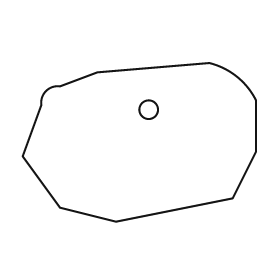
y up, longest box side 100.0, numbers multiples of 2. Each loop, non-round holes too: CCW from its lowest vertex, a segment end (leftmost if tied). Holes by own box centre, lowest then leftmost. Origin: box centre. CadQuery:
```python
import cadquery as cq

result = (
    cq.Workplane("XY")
    .moveTo(-10.0, -34.0)
    .lineTo(40.0, -24.0)
    .lineTo(50.0, -4.0)
    .lineTo(50.0, 18.0)
    .threePointArc((42.0, 28.0), (30.0, 34.0))
    .lineTo(-18.0, 30.0)
    .lineTo(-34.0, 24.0)
    .threePointArc((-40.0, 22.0), (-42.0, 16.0))
    .lineTo(-50.0, -6.0)
    .lineTo(-34.0, -28.0)
    .close()
    .moveTo(4.0, 14.0)
    .circle(4.0)
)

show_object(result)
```